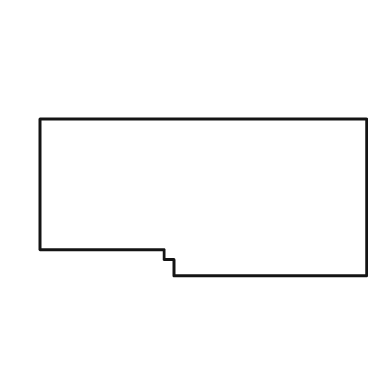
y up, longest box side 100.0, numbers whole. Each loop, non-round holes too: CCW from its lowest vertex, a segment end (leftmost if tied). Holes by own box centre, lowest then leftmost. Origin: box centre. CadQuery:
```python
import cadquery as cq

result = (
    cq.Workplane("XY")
    .moveTo(-9.0, -24.0)
    .lineTo(50.0, -24.0)
    .lineTo(50.0, 24.0)
    .lineTo(-50.0, 24.0)
    .lineTo(-50.0, -16.0)
    .lineTo(-12.0, -16.0)
    .lineTo(-12.0, -19.0)
    .lineTo(-9.0, -19.0)
    .close()
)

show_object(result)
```